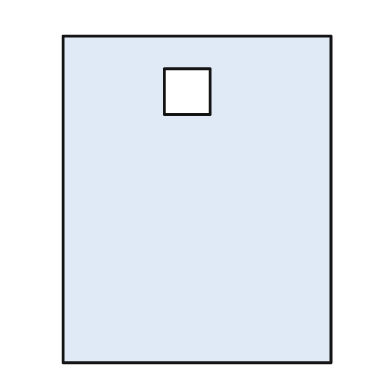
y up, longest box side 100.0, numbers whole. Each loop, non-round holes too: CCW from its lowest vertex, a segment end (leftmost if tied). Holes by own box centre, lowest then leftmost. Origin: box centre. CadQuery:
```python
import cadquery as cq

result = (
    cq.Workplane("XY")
    .moveTo(-41.0, -50.0)
    .lineTo(41.0, -50.0)
    .lineTo(41.0, 50.0)
    .lineTo(-41.0, 50.0)
    .close()
    .moveTo(-10.0, 26.0)
    .lineTo(4.0, 26.0)
    .lineTo(4.0, 40.0)
    .lineTo(-10.0, 40.0)
    .close()
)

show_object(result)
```